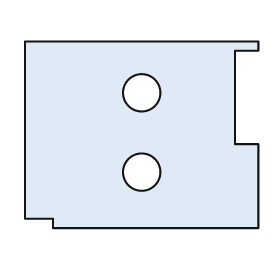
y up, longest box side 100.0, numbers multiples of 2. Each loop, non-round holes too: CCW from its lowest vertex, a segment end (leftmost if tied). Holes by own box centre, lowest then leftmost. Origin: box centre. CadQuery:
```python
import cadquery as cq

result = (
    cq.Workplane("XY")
    .moveTo(-38.0, -40.0)
    .lineTo(50.0, -40.0)
    .lineTo(50.0, -4.0)
    .lineTo(40.0, -4.0)
    .lineTo(40.0, 36.0)
    .lineTo(50.0, 36.0)
    .lineTo(50.0, 40.0)
    .lineTo(-50.0, 40.0)
    .lineTo(-50.0, -36.0)
    .lineTo(-38.0, -36.0)
    .close()
    .moveTo(0.0, -16.0)
    .circle(8.0)
    .moveTo(0.0, 18.0)
    .circle(8.0)
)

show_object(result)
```